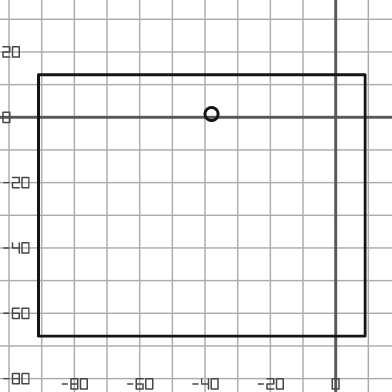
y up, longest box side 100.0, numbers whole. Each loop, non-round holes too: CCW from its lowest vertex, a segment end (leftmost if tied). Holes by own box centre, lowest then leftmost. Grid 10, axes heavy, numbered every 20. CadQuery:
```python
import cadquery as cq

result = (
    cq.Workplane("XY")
    .moveTo(-91.0, -67.0)
    .lineTo(9.0, -67.0)
    .lineTo(9.0, 13.0)
    .lineTo(-91.0, 13.0)
    .close()
    .moveTo(-38.0, 1.0)
    .circle(2.0)
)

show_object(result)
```